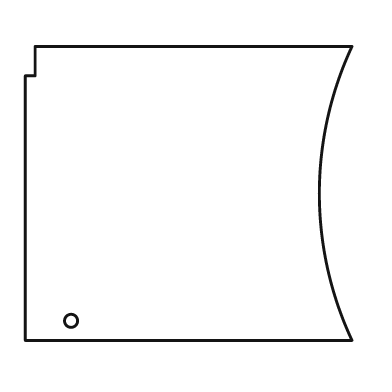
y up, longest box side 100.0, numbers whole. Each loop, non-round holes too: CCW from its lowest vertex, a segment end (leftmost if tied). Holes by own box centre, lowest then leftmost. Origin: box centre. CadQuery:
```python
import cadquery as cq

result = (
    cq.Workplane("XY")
    .moveTo(-50.0, -45.0)
    .lineTo(50.0, -45.0)
    .threePointArc((40.0, 0.0), (50.0, 45.0))
    .lineTo(-47.0, 45.0)
    .lineTo(-47.0, 36.0)
    .lineTo(-50.0, 36.0)
    .close()
    .moveTo(-36.0, -39.0)
    .circle(2.0)
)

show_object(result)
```